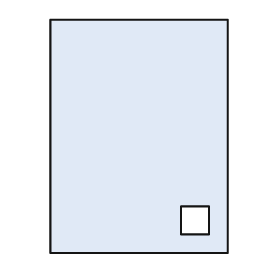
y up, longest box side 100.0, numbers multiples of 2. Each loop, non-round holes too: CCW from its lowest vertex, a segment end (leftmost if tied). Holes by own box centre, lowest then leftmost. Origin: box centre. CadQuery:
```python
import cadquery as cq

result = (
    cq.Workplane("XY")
    .moveTo(-38.0, -50.0)
    .lineTo(38.0, -50.0)
    .lineTo(38.0, 50.0)
    .lineTo(-38.0, 50.0)
    .close()
    .moveTo(18.0, -42.0)
    .lineTo(30.0, -42.0)
    .lineTo(30.0, -30.0)
    .lineTo(18.0, -30.0)
    .close()
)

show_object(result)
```